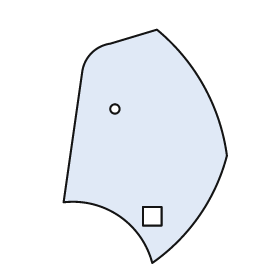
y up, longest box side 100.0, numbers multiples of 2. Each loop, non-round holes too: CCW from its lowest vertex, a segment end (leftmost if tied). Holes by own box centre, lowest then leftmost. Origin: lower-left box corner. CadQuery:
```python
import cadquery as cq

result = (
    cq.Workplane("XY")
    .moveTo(38.0, 0.0)
    .threePointArc((58.0, 20.0), (70.0, 46.0))
    .threePointArc((60.0, 76.0), (40.0, 100.0))
    .lineTo(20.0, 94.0)
    .threePointArc((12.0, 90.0), (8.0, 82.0))
    .lineTo(0.0, 26.0)
    .threePointArc((24.0, 20.0), (38.0, 0.0))
    .close()
    .moveTo(34.0, 16.0)
    .lineTo(42.0, 16.0)
    .lineTo(42.0, 24.0)
    .lineTo(34.0, 24.0)
    .close()
    .moveTo(22.0, 66.0)
    .circle(2.0)
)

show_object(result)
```